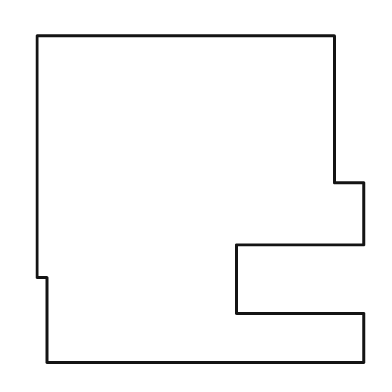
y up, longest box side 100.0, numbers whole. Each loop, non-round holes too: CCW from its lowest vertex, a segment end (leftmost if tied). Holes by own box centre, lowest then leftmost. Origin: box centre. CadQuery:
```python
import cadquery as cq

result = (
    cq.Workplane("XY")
    .moveTo(-47.0, -50.0)
    .lineTo(50.0, -50.0)
    .lineTo(50.0, -35.0)
    .lineTo(11.0, -35.0)
    .lineTo(11.0, -14.0)
    .lineTo(50.0, -14.0)
    .lineTo(50.0, 5.0)
    .lineTo(41.0, 5.0)
    .lineTo(41.0, 50.0)
    .lineTo(-50.0, 50.0)
    .lineTo(-50.0, -24.0)
    .lineTo(-47.0, -24.0)
    .close()
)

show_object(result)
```